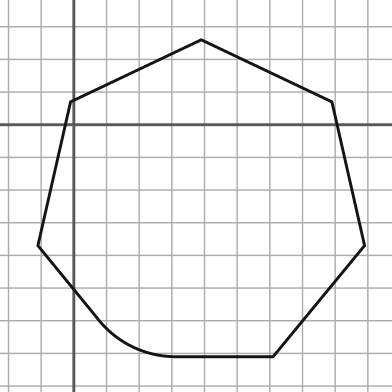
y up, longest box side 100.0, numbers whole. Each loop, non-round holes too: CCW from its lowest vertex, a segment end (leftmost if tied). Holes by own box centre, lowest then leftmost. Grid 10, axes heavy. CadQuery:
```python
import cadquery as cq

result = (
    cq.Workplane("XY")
    .moveTo(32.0, -71.0)
    .lineTo(61.0, -71.0)
    .lineTo(89.0, -37.0)
    .lineTo(79.0, 7.0)
    .lineTo(39.0, 26.0)
    .lineTo(-1.0, 7.0)
    .lineTo(-11.0, -37.0)
    .lineTo(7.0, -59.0)
    .threePointArc((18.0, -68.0), (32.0, -71.0))
    .close()
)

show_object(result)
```